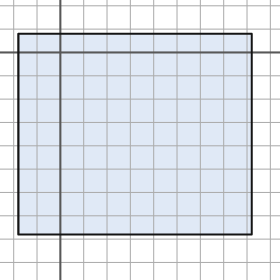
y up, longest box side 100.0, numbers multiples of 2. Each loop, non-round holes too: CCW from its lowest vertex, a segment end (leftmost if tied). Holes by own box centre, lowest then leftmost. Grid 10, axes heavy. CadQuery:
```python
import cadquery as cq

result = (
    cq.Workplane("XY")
    .moveTo(-18.0, -78.0)
    .lineTo(82.0, -78.0)
    .lineTo(82.0, 8.0)
    .lineTo(-18.0, 8.0)
    .close()
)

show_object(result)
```